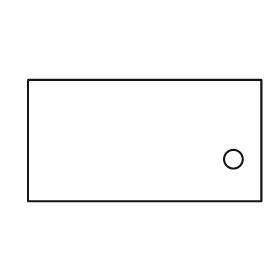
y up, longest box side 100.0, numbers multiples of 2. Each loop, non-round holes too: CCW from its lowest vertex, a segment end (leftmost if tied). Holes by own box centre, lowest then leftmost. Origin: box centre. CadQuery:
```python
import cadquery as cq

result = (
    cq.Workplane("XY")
    .moveTo(-50.0, -26.0)
    .lineTo(50.0, -26.0)
    .lineTo(50.0, 26.0)
    .lineTo(-50.0, 26.0)
    .close()
    .moveTo(38.0, -8.0)
    .circle(4.0)
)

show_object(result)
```